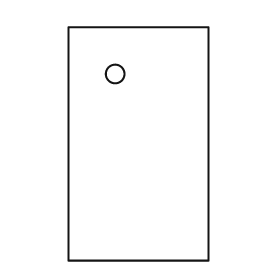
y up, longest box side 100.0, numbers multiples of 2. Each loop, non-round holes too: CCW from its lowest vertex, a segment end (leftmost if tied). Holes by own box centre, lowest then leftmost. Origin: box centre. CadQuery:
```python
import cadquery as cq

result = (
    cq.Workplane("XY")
    .moveTo(-30.0, -50.0)
    .lineTo(30.0, -50.0)
    .lineTo(30.0, 50.0)
    .lineTo(-30.0, 50.0)
    .close()
    .moveTo(-10.0, 30.0)
    .circle(4.0)
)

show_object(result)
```